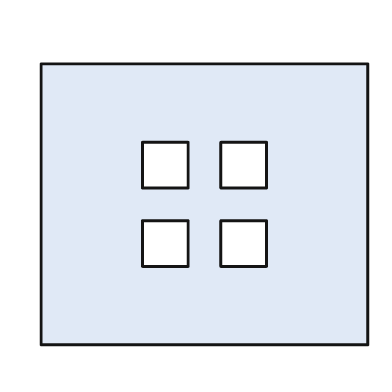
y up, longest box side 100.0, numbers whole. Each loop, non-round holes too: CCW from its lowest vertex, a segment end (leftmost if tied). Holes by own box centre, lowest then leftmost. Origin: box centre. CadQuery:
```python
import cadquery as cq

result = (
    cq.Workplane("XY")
    .moveTo(-50.0, -43.0)
    .lineTo(50.0, -43.0)
    .lineTo(50.0, 43.0)
    .lineTo(-50.0, 43.0)
    .close()
    .moveTo(-19.0, -19.0)
    .lineTo(-5.0, -19.0)
    .lineTo(-5.0, -5.0)
    .lineTo(-19.0, -5.0)
    .close()
    .moveTo(5.0, -19.0)
    .lineTo(19.0, -19.0)
    .lineTo(19.0, -5.0)
    .lineTo(5.0, -5.0)
    .close()
    .moveTo(-19.0, 5.0)
    .lineTo(-5.0, 5.0)
    .lineTo(-5.0, 19.0)
    .lineTo(-19.0, 19.0)
    .close()
    .moveTo(5.0, 5.0)
    .lineTo(19.0, 5.0)
    .lineTo(19.0, 19.0)
    .lineTo(5.0, 19.0)
    .close()
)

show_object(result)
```